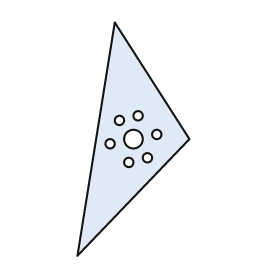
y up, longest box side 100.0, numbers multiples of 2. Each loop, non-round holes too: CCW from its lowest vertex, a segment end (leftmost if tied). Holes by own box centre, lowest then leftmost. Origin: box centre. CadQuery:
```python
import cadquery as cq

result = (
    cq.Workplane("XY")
    .moveTo(-24.0, -50.0)
    .lineTo(24.0, 0.0)
    .lineTo(-8.0, 50.0)
    .close()
    .moveTo(-2.0, -10.0)
    .circle(2.0)
    .moveTo(6.0, -8.0)
    .circle(2.0)
    .moveTo(-10.0, -2.0)
    .circle(2.0)
    .moveTo(0.0, 0.0)
    .circle(4.0)
    .moveTo(10.0, 2.0)
    .circle(2.0)
    .moveTo(-6.0, 8.0)
    .circle(2.0)
    .moveTo(2.0, 10.0)
    .circle(2.0)
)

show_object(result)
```